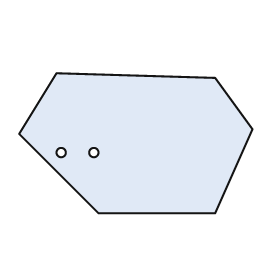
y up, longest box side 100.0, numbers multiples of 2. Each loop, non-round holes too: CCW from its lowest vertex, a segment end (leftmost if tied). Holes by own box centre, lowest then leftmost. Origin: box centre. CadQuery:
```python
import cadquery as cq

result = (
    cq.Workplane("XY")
    .moveTo(-16.0, -30.0)
    .lineTo(34.0, -30.0)
    .lineTo(50.0, 6.0)
    .lineTo(34.0, 28.0)
    .lineTo(-34.0, 30.0)
    .lineTo(-50.0, 4.0)
    .close()
    .moveTo(-32.0, -4.0)
    .circle(2.0)
    .moveTo(-18.0, -4.0)
    .circle(2.0)
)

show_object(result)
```